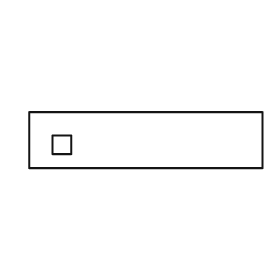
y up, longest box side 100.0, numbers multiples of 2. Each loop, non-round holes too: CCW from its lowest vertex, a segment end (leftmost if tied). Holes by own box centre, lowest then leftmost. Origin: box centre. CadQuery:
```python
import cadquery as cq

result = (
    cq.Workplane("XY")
    .moveTo(-50.0, -12.0)
    .lineTo(50.0, -12.0)
    .lineTo(50.0, 12.0)
    .lineTo(-50.0, 12.0)
    .close()
    .moveTo(-40.0, -6.0)
    .lineTo(-32.0, -6.0)
    .lineTo(-32.0, 2.0)
    .lineTo(-40.0, 2.0)
    .close()
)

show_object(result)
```